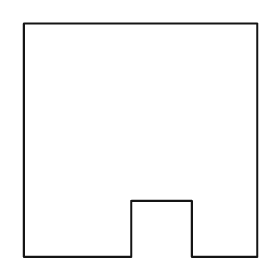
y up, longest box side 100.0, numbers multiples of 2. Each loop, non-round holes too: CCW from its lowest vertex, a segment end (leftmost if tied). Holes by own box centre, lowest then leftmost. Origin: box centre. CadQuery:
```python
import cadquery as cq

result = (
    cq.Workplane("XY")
    .moveTo(-50.0, -50.0)
    .lineTo(-4.0, -50.0)
    .lineTo(-4.0, -26.0)
    .lineTo(22.0, -26.0)
    .lineTo(22.0, -50.0)
    .lineTo(50.0, -50.0)
    .lineTo(50.0, 50.0)
    .lineTo(-50.0, 50.0)
    .close()
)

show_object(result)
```